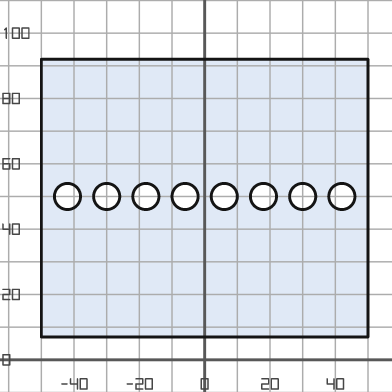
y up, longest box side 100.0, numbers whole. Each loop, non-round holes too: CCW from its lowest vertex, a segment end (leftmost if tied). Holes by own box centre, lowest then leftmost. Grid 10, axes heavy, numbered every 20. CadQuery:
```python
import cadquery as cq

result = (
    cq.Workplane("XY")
    .moveTo(-50.0, 7.0)
    .lineTo(50.0, 7.0)
    .lineTo(50.0, 92.0)
    .lineTo(-50.0, 92.0)
    .close()
    .moveTo(-42.0, 50.0)
    .circle(4.0)
    .moveTo(-30.0, 50.0)
    .circle(4.0)
    .moveTo(-18.0, 50.0)
    .circle(4.0)
    .moveTo(-6.0, 50.0)
    .circle(4.0)
    .moveTo(6.0, 50.0)
    .circle(4.0)
    .moveTo(18.0, 50.0)
    .circle(4.0)
    .moveTo(30.0, 50.0)
    .circle(4.0)
    .moveTo(42.0, 50.0)
    .circle(4.0)
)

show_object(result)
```